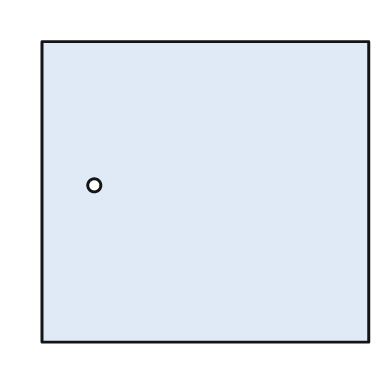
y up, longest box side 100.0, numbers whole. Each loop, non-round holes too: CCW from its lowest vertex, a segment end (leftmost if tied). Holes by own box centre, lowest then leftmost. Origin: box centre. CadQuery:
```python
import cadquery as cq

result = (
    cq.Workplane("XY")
    .moveTo(-50.0, -46.0)
    .lineTo(50.0, -46.0)
    .lineTo(50.0, 46.0)
    .lineTo(-50.0, 46.0)
    .close()
    .moveTo(-34.0, 2.0)
    .circle(2.0)
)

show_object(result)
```